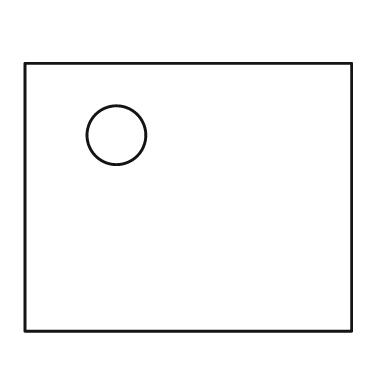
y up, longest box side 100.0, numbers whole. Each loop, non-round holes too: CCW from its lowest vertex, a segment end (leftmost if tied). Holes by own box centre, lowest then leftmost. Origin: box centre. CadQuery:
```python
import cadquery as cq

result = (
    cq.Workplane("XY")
    .moveTo(-50.0, -41.0)
    .lineTo(50.0, -41.0)
    .lineTo(50.0, 41.0)
    .lineTo(-50.0, 41.0)
    .close()
    .moveTo(-22.0, 19.0)
    .circle(9.0)
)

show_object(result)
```